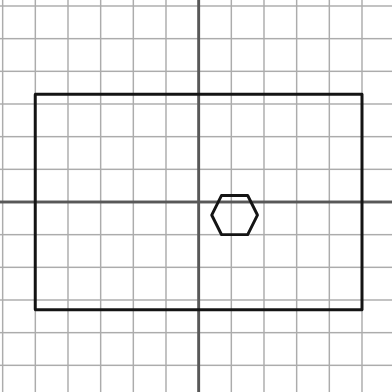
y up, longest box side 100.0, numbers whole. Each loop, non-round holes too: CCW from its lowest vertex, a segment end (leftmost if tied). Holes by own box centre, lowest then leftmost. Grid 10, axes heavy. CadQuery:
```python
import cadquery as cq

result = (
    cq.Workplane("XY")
    .moveTo(-50.0, -33.0)
    .lineTo(50.0, -33.0)
    .lineTo(50.0, 33.0)
    .lineTo(-50.0, 33.0)
    .close()
    .moveTo(7.0, -10.0)
    .lineTo(15.0, -10.0)
    .lineTo(18.0, -4.0)
    .lineTo(15.0, 2.0)
    .lineTo(7.0, 2.0)
    .lineTo(4.0, -4.0)
    .close()
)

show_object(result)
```